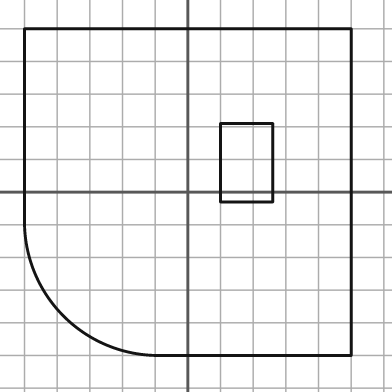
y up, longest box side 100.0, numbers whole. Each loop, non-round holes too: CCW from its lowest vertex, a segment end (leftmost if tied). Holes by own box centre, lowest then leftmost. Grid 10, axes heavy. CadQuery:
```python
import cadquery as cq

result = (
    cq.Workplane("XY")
    .moveTo(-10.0, -50.0)
    .lineTo(50.0, -50.0)
    .lineTo(50.0, 50.0)
    .lineTo(-50.0, 50.0)
    .lineTo(-50.0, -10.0)
    .threePointArc((-38.0, -38.0), (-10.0, -50.0))
    .close()
    .moveTo(10.0, -3.0)
    .lineTo(26.0, -3.0)
    .lineTo(26.0, 21.0)
    .lineTo(10.0, 21.0)
    .close()
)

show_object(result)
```